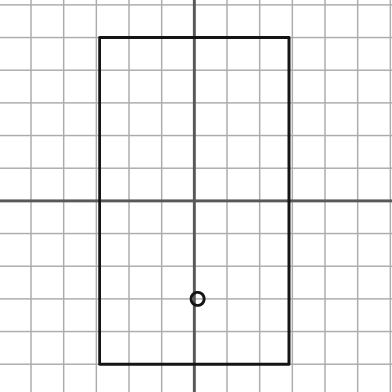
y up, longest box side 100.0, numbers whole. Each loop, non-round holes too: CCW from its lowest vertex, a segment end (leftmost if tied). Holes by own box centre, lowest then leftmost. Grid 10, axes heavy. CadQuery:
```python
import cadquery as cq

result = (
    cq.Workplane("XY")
    .moveTo(-29.0, -50.0)
    .lineTo(29.0, -50.0)
    .lineTo(29.0, 50.0)
    .lineTo(-29.0, 50.0)
    .close()
    .moveTo(1.0, -30.0)
    .circle(2.0)
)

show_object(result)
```